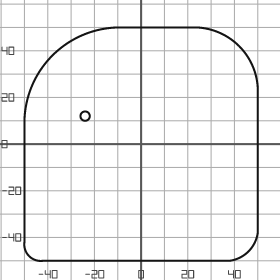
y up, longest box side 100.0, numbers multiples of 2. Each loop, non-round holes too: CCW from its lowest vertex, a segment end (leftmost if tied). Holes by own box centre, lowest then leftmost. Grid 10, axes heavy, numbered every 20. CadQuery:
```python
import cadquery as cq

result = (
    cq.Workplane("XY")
    .moveTo(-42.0, -50.0)
    .lineTo(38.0, -50.0)
    .threePointArc((46.0, -46.0), (50.0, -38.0))
    .lineTo(50.0, 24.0)
    .threePointArc((42.0, 42.0), (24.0, 50.0))
    .lineTo(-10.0, 50.0)
    .threePointArc((-38.0, 38.0), (-50.0, 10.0))
    .lineTo(-50.0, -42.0)
    .threePointArc((-48.0, -48.0), (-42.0, -50.0))
    .close()
    .moveTo(-24.0, 12.0)
    .circle(2.0)
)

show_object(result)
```